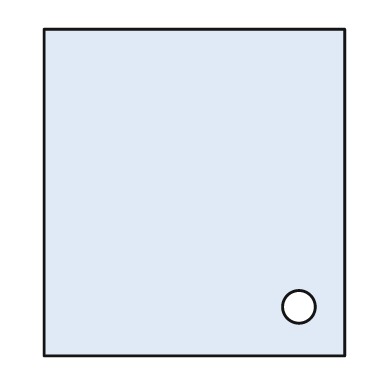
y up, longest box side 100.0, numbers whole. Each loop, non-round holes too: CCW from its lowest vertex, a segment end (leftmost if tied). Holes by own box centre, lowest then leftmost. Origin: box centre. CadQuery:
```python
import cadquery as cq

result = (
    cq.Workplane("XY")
    .moveTo(-46.0, -50.0)
    .lineTo(46.0, -50.0)
    .lineTo(46.0, 50.0)
    .lineTo(-46.0, 50.0)
    .close()
    .moveTo(32.0, -35.0)
    .circle(5.0)
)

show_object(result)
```